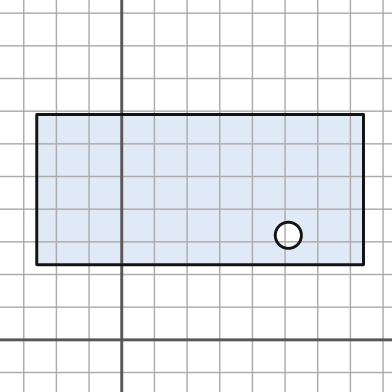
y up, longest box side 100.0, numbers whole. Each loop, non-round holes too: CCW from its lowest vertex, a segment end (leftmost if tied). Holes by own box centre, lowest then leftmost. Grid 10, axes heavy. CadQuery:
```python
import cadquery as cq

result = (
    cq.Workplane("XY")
    .moveTo(-26.0, 23.0)
    .lineTo(74.0, 23.0)
    .lineTo(74.0, 69.0)
    .lineTo(-26.0, 69.0)
    .close()
    .moveTo(51.0, 32.0)
    .circle(4.0)
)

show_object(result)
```